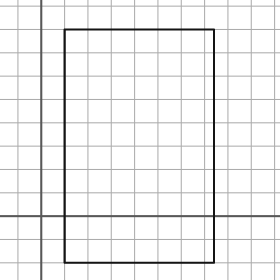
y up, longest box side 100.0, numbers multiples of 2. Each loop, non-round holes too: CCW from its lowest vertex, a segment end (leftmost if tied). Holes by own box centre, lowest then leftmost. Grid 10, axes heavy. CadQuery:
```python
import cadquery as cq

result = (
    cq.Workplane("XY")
    .moveTo(10.0, -20.0)
    .lineTo(74.0, -20.0)
    .lineTo(74.0, 80.0)
    .lineTo(10.0, 80.0)
    .close()
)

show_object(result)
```